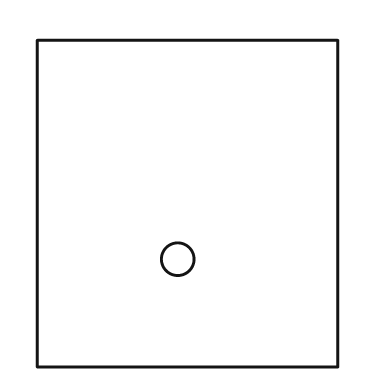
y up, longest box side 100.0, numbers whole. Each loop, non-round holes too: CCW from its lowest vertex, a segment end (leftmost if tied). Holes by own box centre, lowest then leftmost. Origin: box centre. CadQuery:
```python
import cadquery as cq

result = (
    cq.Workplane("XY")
    .moveTo(-46.0, -50.0)
    .lineTo(46.0, -50.0)
    .lineTo(46.0, 50.0)
    .lineTo(-46.0, 50.0)
    .close()
    .moveTo(-3.0, -17.0)
    .circle(5.0)
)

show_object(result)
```